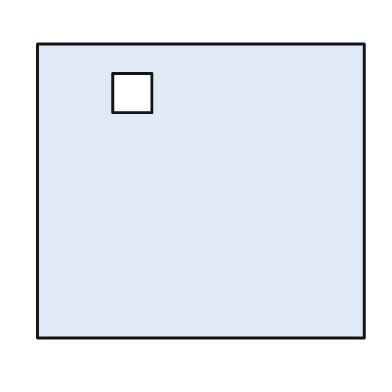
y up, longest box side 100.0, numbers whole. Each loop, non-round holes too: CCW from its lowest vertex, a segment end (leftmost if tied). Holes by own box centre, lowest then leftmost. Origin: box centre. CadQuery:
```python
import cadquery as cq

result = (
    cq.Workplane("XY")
    .moveTo(-50.0, -45.0)
    .lineTo(50.0, -45.0)
    .lineTo(50.0, 45.0)
    .lineTo(-50.0, 45.0)
    .close()
    .moveTo(-27.0, 24.0)
    .lineTo(-15.0, 24.0)
    .lineTo(-15.0, 36.0)
    .lineTo(-27.0, 36.0)
    .close()
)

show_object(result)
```